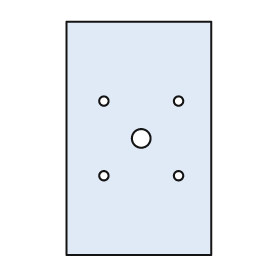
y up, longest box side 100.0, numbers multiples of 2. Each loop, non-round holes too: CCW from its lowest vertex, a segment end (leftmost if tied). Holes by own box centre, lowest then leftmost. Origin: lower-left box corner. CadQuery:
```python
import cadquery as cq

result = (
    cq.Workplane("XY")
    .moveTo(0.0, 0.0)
    .lineTo(62.0, 0.0)
    .lineTo(62.0, 100.0)
    .lineTo(0.0, 100.0)
    .close()
    .moveTo(16.0, 34.0)
    .circle(2.0)
    .moveTo(48.0, 34.0)
    .circle(2.0)
    .moveTo(32.0, 50.0)
    .circle(4.0)
    .moveTo(16.0, 66.0)
    .circle(2.0)
    .moveTo(48.0, 66.0)
    .circle(2.0)
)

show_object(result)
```